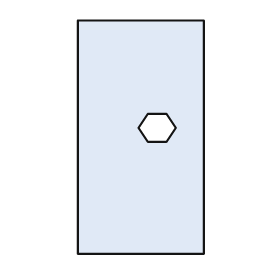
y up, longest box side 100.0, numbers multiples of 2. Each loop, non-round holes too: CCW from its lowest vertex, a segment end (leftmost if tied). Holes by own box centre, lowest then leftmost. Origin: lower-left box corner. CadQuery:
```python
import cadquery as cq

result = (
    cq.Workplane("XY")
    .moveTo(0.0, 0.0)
    .lineTo(54.0, 0.0)
    .lineTo(54.0, 100.0)
    .lineTo(0.0, 100.0)
    .close()
    .moveTo(30.0, 48.0)
    .lineTo(38.0, 48.0)
    .lineTo(42.0, 54.0)
    .lineTo(38.0, 60.0)
    .lineTo(30.0, 60.0)
    .lineTo(26.0, 54.0)
    .close()
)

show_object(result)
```